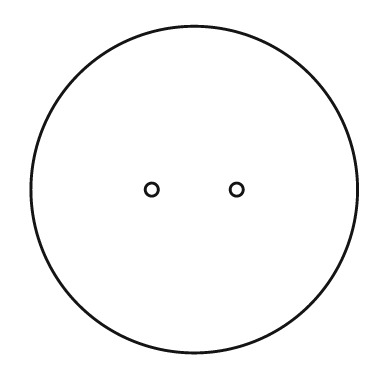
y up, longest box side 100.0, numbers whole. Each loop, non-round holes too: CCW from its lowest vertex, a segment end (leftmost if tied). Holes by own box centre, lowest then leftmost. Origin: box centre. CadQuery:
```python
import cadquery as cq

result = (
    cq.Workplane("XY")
    .moveTo(0.0, 0.0)
    .circle(50.0)
    .moveTo(-13.0, 0.0)
    .circle(2.0)
    .moveTo(13.0, 0.0)
    .circle(2.0)
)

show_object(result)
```